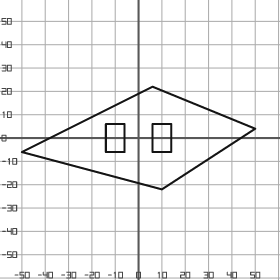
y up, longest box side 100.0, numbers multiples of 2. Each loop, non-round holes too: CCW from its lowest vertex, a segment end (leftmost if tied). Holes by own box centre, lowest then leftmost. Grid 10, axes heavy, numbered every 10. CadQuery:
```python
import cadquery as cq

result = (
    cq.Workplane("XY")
    .moveTo(10.0, -22.0)
    .lineTo(50.0, 4.0)
    .lineTo(6.0, 22.0)
    .lineTo(-50.0, -6.0)
    .close()
    .moveTo(-14.0, -6.0)
    .lineTo(-6.0, -6.0)
    .lineTo(-6.0, 6.0)
    .lineTo(-14.0, 6.0)
    .close()
    .moveTo(6.0, -6.0)
    .lineTo(14.0, -6.0)
    .lineTo(14.0, 6.0)
    .lineTo(6.0, 6.0)
    .close()
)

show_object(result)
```